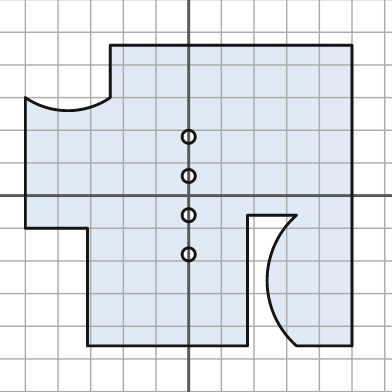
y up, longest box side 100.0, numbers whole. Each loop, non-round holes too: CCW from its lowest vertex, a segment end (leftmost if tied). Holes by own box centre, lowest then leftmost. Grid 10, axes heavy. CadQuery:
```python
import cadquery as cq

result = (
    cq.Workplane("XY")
    .moveTo(-31.0, -46.0)
    .lineTo(18.0, -46.0)
    .lineTo(18.0, -6.0)
    .lineTo(33.0, -6.0)
    .threePointArc((24.0, -26.0), (33.0, -46.0))
    .lineTo(50.0, -46.0)
    .lineTo(50.0, 46.0)
    .lineTo(-24.0, 46.0)
    .lineTo(-24.0, 30.0)
    .threePointArc((-37.0, 26.0), (-50.0, 30.0))
    .lineTo(-50.0, -10.0)
    .lineTo(-31.0, -10.0)
    .close()
    .moveTo(0.0, -18.0)
    .circle(2.0)
    .moveTo(0.0, -6.0)
    .circle(2.0)
    .moveTo(0.0, 6.0)
    .circle(2.0)
    .moveTo(0.0, 18.0)
    .circle(2.0)
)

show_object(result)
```